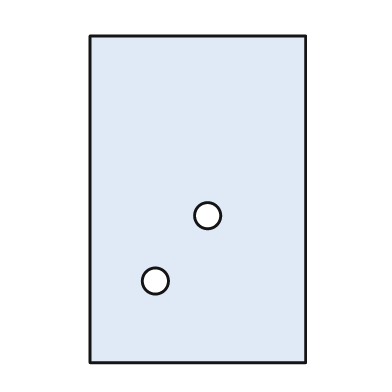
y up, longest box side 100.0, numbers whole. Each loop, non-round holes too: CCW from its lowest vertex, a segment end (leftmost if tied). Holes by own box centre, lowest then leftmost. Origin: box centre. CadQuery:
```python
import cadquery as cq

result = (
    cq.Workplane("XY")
    .moveTo(-33.0, -50.0)
    .lineTo(33.0, -50.0)
    .lineTo(33.0, 50.0)
    .lineTo(-33.0, 50.0)
    .close()
    .moveTo(-13.0, -25.0)
    .circle(4.0)
    .moveTo(3.0, -5.0)
    .circle(4.0)
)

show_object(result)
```